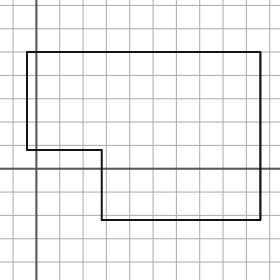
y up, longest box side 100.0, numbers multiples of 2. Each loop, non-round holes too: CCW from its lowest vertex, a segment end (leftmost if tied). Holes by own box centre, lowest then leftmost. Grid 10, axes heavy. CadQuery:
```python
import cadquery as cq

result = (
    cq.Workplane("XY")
    .moveTo(28.0, -22.0)
    .lineTo(96.0, -22.0)
    .lineTo(96.0, 50.0)
    .lineTo(-4.0, 50.0)
    .lineTo(-4.0, 8.0)
    .lineTo(28.0, 8.0)
    .close()
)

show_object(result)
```